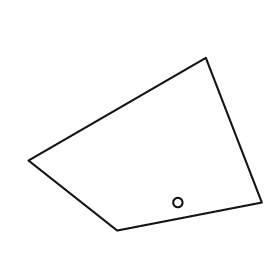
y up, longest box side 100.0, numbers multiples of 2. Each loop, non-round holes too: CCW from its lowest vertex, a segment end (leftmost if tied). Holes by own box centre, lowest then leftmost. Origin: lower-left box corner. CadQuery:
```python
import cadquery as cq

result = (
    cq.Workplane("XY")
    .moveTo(38.0, 0.0)
    .lineTo(100.0, 12.0)
    .lineTo(76.0, 74.0)
    .lineTo(0.0, 30.0)
    .close()
    .moveTo(64.0, 12.0)
    .circle(2.0)
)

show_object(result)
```